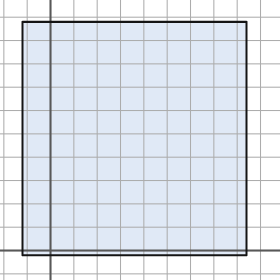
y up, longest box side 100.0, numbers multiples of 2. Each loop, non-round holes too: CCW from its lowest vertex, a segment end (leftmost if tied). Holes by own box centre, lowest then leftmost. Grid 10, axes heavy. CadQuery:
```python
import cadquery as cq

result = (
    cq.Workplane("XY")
    .moveTo(-12.0, -2.0)
    .lineTo(84.0, -2.0)
    .lineTo(84.0, 98.0)
    .lineTo(-12.0, 98.0)
    .close()
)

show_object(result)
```